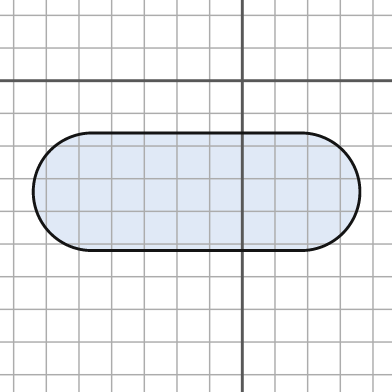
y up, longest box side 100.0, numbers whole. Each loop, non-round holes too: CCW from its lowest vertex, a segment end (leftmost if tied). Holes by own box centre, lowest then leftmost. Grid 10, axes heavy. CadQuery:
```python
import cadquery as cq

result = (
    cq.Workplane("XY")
    .moveTo(-46.0, -52.0)
    .lineTo(18.0, -52.0)
    .threePointArc((36.0, -34.0), (18.0, -16.0))
    .lineTo(-46.0, -16.0)
    .threePointArc((-64.0, -34.0), (-46.0, -52.0))
    .close()
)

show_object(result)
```